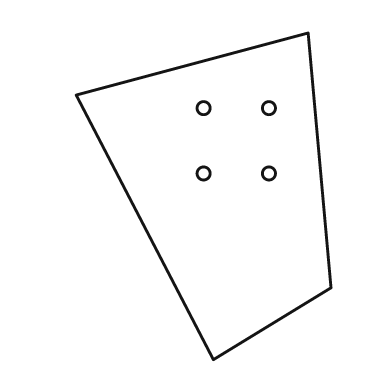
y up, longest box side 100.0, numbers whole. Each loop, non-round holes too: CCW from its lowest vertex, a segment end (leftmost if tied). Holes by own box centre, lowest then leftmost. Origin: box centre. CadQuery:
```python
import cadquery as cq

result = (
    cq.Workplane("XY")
    .moveTo(3.0, -50.0)
    .lineTo(39.0, -28.0)
    .lineTo(32.0, 50.0)
    .lineTo(-39.0, 31.0)
    .close()
    .moveTo(0.0, 7.0)
    .circle(2.0)
    .moveTo(20.0, 7.0)
    .circle(2.0)
    .moveTo(0.0, 27.0)
    .circle(2.0)
    .moveTo(20.0, 27.0)
    .circle(2.0)
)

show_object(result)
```